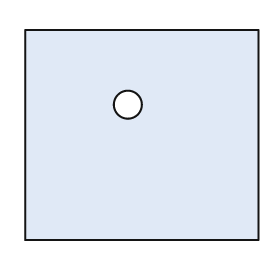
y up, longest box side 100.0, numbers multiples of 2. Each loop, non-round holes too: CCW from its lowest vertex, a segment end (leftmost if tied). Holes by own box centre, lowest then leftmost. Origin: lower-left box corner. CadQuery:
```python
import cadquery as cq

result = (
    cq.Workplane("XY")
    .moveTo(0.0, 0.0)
    .lineTo(100.0, 0.0)
    .lineTo(100.0, 90.0)
    .lineTo(0.0, 90.0)
    .close()
    .moveTo(44.0, 58.0)
    .circle(6.0)
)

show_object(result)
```